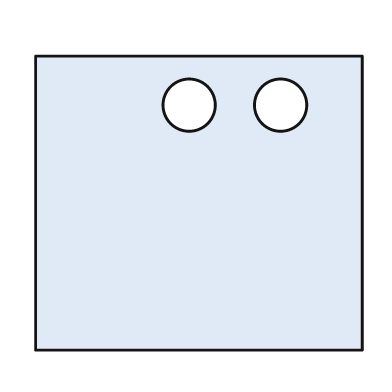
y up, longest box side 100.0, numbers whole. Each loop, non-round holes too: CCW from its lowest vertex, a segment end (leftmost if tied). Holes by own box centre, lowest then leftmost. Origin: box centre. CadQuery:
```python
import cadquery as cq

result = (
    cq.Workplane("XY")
    .moveTo(-50.0, -45.0)
    .lineTo(50.0, -45.0)
    .lineTo(50.0, 45.0)
    .lineTo(-50.0, 45.0)
    .close()
    .moveTo(-3.0, 30.0)
    .circle(8.0)
    .moveTo(25.0, 30.0)
    .circle(8.0)
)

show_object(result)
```